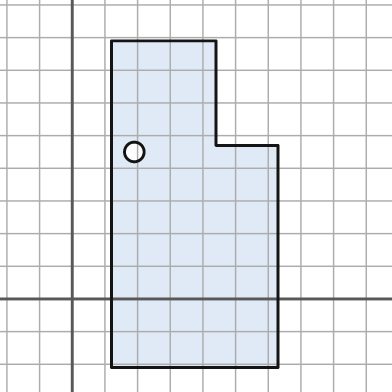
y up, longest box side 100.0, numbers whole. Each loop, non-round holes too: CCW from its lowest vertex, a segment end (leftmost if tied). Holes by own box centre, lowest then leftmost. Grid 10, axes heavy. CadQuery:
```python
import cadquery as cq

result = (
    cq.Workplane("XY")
    .moveTo(12.0, -21.0)
    .lineTo(63.0, -21.0)
    .lineTo(63.0, 47.0)
    .lineTo(44.0, 47.0)
    .lineTo(44.0, 79.0)
    .lineTo(12.0, 79.0)
    .close()
    .moveTo(19.0, 45.0)
    .circle(3.0)
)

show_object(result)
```